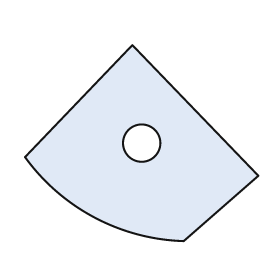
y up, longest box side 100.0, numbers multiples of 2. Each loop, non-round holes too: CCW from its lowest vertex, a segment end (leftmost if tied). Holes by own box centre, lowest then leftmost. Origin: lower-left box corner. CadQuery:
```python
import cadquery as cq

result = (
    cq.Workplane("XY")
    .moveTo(68.0, 0.0)
    .lineTo(100.0, 28.0)
    .lineTo(46.0, 84.0)
    .lineTo(0.0, 36.0)
    .threePointArc((30.0, 10.0), (68.0, 0.0))
    .close()
    .moveTo(50.0, 42.0)
    .circle(8.0)
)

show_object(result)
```